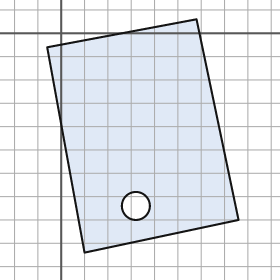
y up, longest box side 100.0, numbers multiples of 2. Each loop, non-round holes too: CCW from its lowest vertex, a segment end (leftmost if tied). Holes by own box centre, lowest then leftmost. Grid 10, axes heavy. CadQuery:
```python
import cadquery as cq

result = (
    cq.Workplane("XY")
    .moveTo(10.0, -94.0)
    .lineTo(76.0, -80.0)
    .lineTo(58.0, 6.0)
    .lineTo(-6.0, -6.0)
    .close()
    .moveTo(32.0, -74.0)
    .circle(6.0)
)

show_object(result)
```